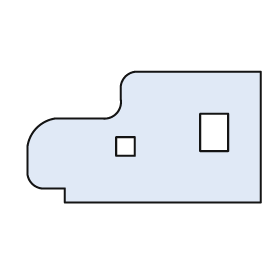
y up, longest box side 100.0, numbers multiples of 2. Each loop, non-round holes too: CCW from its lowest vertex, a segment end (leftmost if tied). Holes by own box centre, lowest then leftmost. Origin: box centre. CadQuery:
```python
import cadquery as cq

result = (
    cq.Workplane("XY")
    .moveTo(-34.0, -28.0)
    .lineTo(50.0, -28.0)
    .lineTo(50.0, 28.0)
    .lineTo(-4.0, 28.0)
    .threePointArc((-8.0, 26.0), (-10.0, 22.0))
    .lineTo(-10.0, 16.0)
    .threePointArc((-12.0, 10.0), (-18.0, 8.0))
    .lineTo(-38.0, 8.0)
    .threePointArc((-46.0, 4.0), (-50.0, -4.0))
    .lineTo(-50.0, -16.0)
    .threePointArc((-48.0, -20.0), (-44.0, -22.0))
    .lineTo(-34.0, -22.0)
    .close()
    .moveTo(-12.0, -8.0)
    .lineTo(-4.0, -8.0)
    .lineTo(-4.0, 0.0)
    .lineTo(-12.0, 0.0)
    .close()
    .moveTo(24.0, -6.0)
    .lineTo(36.0, -6.0)
    .lineTo(36.0, 10.0)
    .lineTo(24.0, 10.0)
    .close()
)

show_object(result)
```